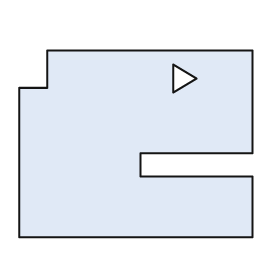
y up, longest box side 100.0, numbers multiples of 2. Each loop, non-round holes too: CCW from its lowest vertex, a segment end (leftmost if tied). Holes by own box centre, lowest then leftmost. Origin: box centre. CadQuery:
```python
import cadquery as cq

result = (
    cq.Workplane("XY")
    .moveTo(-50.0, -40.0)
    .lineTo(50.0, -40.0)
    .lineTo(50.0, -14.0)
    .lineTo(2.0, -14.0)
    .lineTo(2.0, -4.0)
    .lineTo(50.0, -4.0)
    .lineTo(50.0, 40.0)
    .lineTo(-38.0, 40.0)
    .lineTo(-38.0, 24.0)
    .lineTo(-50.0, 24.0)
    .close()
    .moveTo(16.0, 22.0)
    .lineTo(26.0, 28.0)
    .lineTo(16.0, 34.0)
    .close()
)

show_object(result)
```